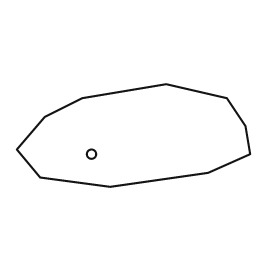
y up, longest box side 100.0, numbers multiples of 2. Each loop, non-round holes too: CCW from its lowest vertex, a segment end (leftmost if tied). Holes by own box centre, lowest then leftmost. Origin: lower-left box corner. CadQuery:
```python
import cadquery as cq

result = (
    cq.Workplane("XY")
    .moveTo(40.0, 0.0)
    .lineTo(82.0, 6.0)
    .lineTo(100.0, 14.0)
    .lineTo(98.0, 26.0)
    .lineTo(90.0, 38.0)
    .lineTo(64.0, 44.0)
    .lineTo(28.0, 38.0)
    .lineTo(12.0, 30.0)
    .lineTo(0.0, 16.0)
    .lineTo(10.0, 4.0)
    .close()
    .moveTo(32.0, 14.0)
    .circle(2.0)
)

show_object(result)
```